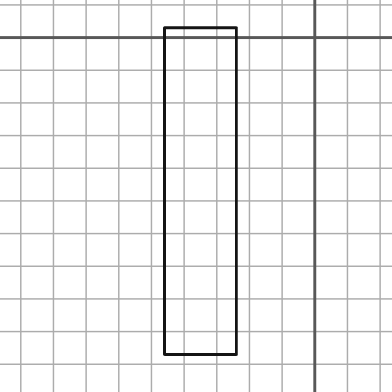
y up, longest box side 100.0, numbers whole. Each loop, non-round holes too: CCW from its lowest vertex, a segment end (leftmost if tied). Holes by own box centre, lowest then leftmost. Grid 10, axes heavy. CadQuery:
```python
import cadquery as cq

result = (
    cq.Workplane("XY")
    .moveTo(-46.0, -97.0)
    .lineTo(-24.0, -97.0)
    .lineTo(-24.0, 3.0)
    .lineTo(-46.0, 3.0)
    .close()
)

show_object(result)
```